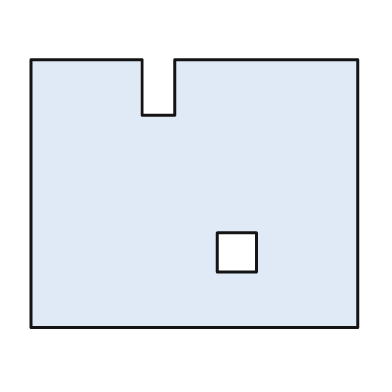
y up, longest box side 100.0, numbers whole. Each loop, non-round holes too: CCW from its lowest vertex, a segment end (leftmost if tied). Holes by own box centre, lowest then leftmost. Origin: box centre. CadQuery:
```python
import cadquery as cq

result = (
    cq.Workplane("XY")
    .moveTo(-50.0, -41.0)
    .lineTo(50.0, -41.0)
    .lineTo(50.0, 41.0)
    .lineTo(-6.0, 41.0)
    .lineTo(-6.0, 24.0)
    .lineTo(-16.0, 24.0)
    .lineTo(-16.0, 41.0)
    .lineTo(-50.0, 41.0)
    .close()
    .moveTo(7.0, -24.0)
    .lineTo(19.0, -24.0)
    .lineTo(19.0, -12.0)
    .lineTo(7.0, -12.0)
    .close()
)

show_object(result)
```